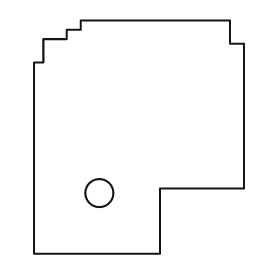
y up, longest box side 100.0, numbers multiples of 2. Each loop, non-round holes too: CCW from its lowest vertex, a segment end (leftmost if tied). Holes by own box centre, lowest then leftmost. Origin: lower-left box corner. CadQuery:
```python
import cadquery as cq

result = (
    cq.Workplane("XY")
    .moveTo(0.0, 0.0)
    .lineTo(54.0, 0.0)
    .lineTo(54.0, 28.0)
    .lineTo(90.0, 28.0)
    .lineTo(90.0, 90.0)
    .lineTo(84.0, 90.0)
    .lineTo(84.0, 100.0)
    .lineTo(20.0, 100.0)
    .lineTo(20.0, 96.0)
    .lineTo(14.0, 96.0)
    .lineTo(14.0, 92.0)
    .lineTo(4.0, 92.0)
    .lineTo(4.0, 82.0)
    .lineTo(0.0, 82.0)
    .close()
    .moveTo(28.0, 26.0)
    .circle(6.0)
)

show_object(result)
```